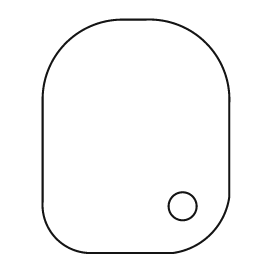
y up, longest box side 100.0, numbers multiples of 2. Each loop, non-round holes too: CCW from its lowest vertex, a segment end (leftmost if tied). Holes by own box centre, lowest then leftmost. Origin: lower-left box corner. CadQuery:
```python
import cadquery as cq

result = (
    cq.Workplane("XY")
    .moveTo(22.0, 0.0)
    .lineTo(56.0, 0.0)
    .threePointArc((72.0, 8.0), (80.0, 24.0))
    .lineTo(80.0, 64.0)
    .threePointArc((70.0, 90.0), (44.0, 100.0))
    .lineTo(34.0, 100.0)
    .threePointArc((10.0, 90.0), (0.0, 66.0))
    .lineTo(0.0, 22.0)
    .threePointArc((6.0, 6.0), (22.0, 0.0))
    .close()
    .moveTo(60.0, 20.0)
    .circle(6.0)
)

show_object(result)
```